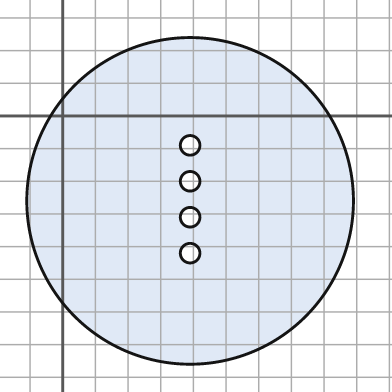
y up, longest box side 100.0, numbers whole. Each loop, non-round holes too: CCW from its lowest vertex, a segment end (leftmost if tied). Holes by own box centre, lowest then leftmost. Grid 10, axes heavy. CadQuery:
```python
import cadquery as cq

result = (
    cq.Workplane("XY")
    .moveTo(39.0, -26.0)
    .circle(50.0)
    .moveTo(39.0, -42.0)
    .circle(3.0)
    .moveTo(39.0, -31.0)
    .circle(3.0)
    .moveTo(39.0, -20.0)
    .circle(3.0)
    .moveTo(39.0, -9.0)
    .circle(3.0)
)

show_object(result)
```